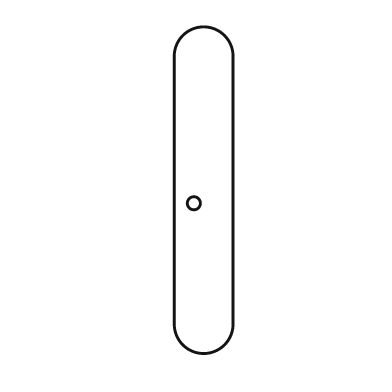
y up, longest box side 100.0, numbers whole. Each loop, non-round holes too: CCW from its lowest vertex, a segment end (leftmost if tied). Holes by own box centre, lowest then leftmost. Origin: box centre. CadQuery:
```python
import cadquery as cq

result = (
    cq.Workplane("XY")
    .moveTo(-9.0, -41.0)
    .threePointArc((0.0, -50.0), (9.0, -41.0))
    .lineTo(9.0, 41.0)
    .threePointArc((0.0, 50.0), (-9.0, 41.0))
    .close()
    .moveTo(-3.0, -4.0)
    .circle(2.0)
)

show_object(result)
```